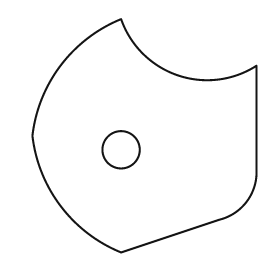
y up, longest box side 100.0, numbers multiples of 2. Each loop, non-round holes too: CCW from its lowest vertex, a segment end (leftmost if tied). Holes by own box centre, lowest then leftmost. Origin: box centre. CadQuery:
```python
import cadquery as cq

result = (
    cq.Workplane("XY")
    .moveTo(-10.0, -50.0)
    .lineTo(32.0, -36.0)
    .threePointArc((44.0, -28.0), (48.0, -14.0))
    .lineTo(48.0, 30.0)
    .threePointArc((14.0, 26.0), (-10.0, 50.0))
    .threePointArc((-36.0, 30.0), (-48.0, 0.0))
    .threePointArc((-36.0, -30.0), (-10.0, -50.0))
    .close()
    .moveTo(-10.0, -6.0)
    .circle(8.0)
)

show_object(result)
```